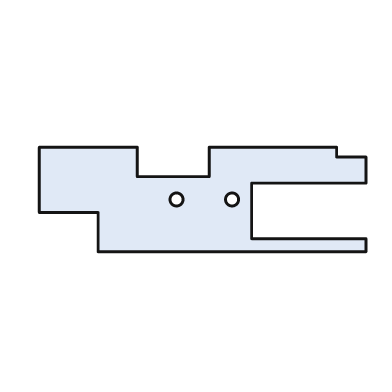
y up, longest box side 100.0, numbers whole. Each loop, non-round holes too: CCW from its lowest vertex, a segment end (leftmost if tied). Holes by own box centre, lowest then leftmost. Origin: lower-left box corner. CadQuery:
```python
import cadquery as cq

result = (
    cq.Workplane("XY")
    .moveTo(18.0, 0.0)
    .lineTo(100.0, 0.0)
    .lineTo(100.0, 4.0)
    .lineTo(65.0, 4.0)
    .lineTo(65.0, 21.0)
    .lineTo(100.0, 21.0)
    .lineTo(100.0, 29.0)
    .lineTo(91.0, 29.0)
    .lineTo(91.0, 32.0)
    .lineTo(52.0, 32.0)
    .lineTo(52.0, 23.0)
    .lineTo(30.0, 23.0)
    .lineTo(30.0, 32.0)
    .lineTo(0.0, 32.0)
    .lineTo(0.0, 12.0)
    .lineTo(18.0, 12.0)
    .close()
    .moveTo(42.0, 16.0)
    .circle(2.0)
    .moveTo(59.0, 16.0)
    .circle(2.0)
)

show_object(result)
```